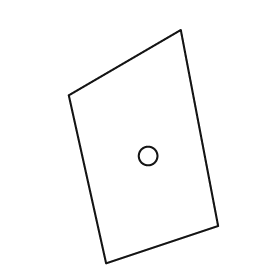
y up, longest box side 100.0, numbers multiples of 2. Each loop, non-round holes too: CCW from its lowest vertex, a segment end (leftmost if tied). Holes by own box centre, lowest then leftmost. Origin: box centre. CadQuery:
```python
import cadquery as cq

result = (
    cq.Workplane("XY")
    .moveTo(-16.0, -50.0)
    .lineTo(32.0, -34.0)
    .lineTo(16.0, 50.0)
    .lineTo(-32.0, 22.0)
    .close()
    .moveTo(2.0, -4.0)
    .circle(4.0)
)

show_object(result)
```